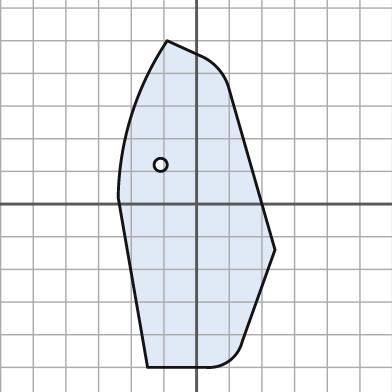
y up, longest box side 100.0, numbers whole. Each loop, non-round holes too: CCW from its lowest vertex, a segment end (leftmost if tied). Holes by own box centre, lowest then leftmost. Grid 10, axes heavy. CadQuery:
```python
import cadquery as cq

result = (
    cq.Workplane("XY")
    .moveTo(-15.0, -50.0)
    .lineTo(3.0, -50.0)
    .threePointArc((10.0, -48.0), (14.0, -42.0))
    .lineTo(24.0, -14.0)
    .lineTo(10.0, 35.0)
    .threePointArc((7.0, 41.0), (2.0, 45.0))
    .lineTo(-9.0, 50.0)
    .threePointArc((-20.0, 27.0), (-24.0, 2.0))
    .close()
    .moveTo(-11.0, 12.0)
    .circle(2.0)
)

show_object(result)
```